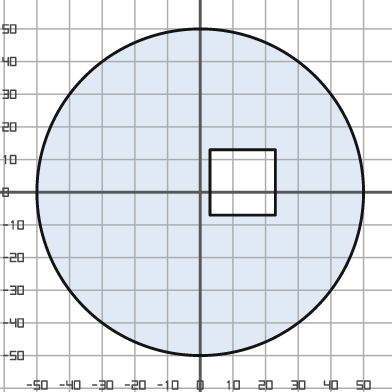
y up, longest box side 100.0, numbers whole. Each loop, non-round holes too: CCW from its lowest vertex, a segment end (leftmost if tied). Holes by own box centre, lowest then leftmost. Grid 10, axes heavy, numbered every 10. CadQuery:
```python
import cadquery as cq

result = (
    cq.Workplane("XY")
    .moveTo(0.0, 0.0)
    .circle(50.0)
    .moveTo(3.0, -7.0)
    .lineTo(23.0, -7.0)
    .lineTo(23.0, 13.0)
    .lineTo(3.0, 13.0)
    .close()
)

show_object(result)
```